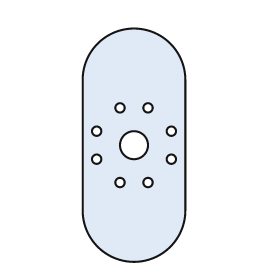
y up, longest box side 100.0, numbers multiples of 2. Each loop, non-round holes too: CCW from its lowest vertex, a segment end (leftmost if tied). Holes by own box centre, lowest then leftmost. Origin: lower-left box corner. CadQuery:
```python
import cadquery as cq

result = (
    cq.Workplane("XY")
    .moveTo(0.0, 22.0)
    .threePointArc((22.0, 0.0), (44.0, 22.0))
    .lineTo(44.0, 78.0)
    .threePointArc((22.0, 100.0), (0.0, 78.0))
    .close()
    .moveTo(16.0, 34.0)
    .circle(2.0)
    .moveTo(28.0, 34.0)
    .circle(2.0)
    .moveTo(6.0, 44.0)
    .circle(2.0)
    .moveTo(38.0, 44.0)
    .circle(2.0)
    .moveTo(22.0, 50.0)
    .circle(6.0)
    .moveTo(6.0, 56.0)
    .circle(2.0)
    .moveTo(38.0, 56.0)
    .circle(2.0)
    .moveTo(16.0, 66.0)
    .circle(2.0)
    .moveTo(28.0, 66.0)
    .circle(2.0)
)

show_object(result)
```